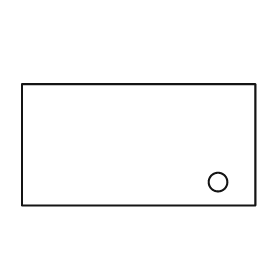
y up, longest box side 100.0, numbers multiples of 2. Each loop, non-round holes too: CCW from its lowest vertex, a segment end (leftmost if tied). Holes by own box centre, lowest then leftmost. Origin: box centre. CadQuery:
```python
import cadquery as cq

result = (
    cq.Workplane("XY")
    .moveTo(-50.0, -26.0)
    .lineTo(50.0, -26.0)
    .lineTo(50.0, 26.0)
    .lineTo(-50.0, 26.0)
    .close()
    .moveTo(34.0, -16.0)
    .circle(4.0)
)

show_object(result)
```